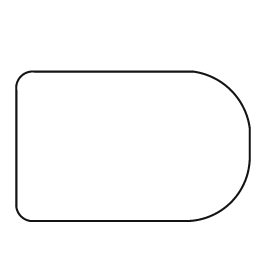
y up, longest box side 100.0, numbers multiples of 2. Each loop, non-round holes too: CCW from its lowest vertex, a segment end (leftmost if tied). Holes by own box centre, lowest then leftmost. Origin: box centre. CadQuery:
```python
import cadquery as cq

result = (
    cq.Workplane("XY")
    .moveTo(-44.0, -32.0)
    .lineTo(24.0, -32.0)
    .threePointArc((42.0, -24.0), (50.0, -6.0))
    .lineTo(50.0, 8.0)
    .threePointArc((42.0, 24.0), (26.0, 32.0))
    .lineTo(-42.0, 32.0)
    .threePointArc((-48.0, 30.0), (-50.0, 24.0))
    .lineTo(-50.0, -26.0)
    .threePointArc((-48.0, -30.0), (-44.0, -32.0))
    .close()
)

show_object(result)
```